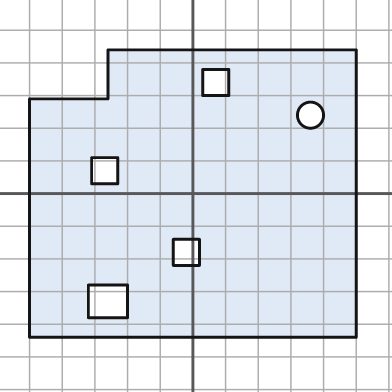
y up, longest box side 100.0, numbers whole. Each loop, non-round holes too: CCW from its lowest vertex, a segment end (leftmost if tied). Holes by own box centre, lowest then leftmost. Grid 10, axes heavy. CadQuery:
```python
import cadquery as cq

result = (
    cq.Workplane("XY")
    .moveTo(-50.0, -44.0)
    .lineTo(50.0, -44.0)
    .lineTo(50.0, 44.0)
    .lineTo(-26.0, 44.0)
    .lineTo(-26.0, 29.0)
    .lineTo(-50.0, 29.0)
    .close()
    .moveTo(-32.0, -38.0)
    .lineTo(-20.0, -38.0)
    .lineTo(-20.0, -28.0)
    .lineTo(-32.0, -28.0)
    .close()
    .moveTo(-6.0, -22.0)
    .lineTo(2.0, -22.0)
    .lineTo(2.0, -14.0)
    .lineTo(-6.0, -14.0)
    .close()
    .moveTo(-31.0, 3.0)
    .lineTo(-23.0, 3.0)
    .lineTo(-23.0, 11.0)
    .lineTo(-31.0, 11.0)
    .close()
    .moveTo(36.0, 24.0)
    .circle(4.0)
    .moveTo(3.0, 30.0)
    .lineTo(11.0, 30.0)
    .lineTo(11.0, 38.0)
    .lineTo(3.0, 38.0)
    .close()
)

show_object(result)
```